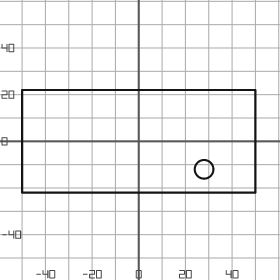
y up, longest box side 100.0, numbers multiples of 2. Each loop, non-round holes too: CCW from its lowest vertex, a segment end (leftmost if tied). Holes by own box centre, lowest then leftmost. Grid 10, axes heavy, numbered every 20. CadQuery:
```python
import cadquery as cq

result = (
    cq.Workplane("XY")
    .moveTo(-50.0, -22.0)
    .lineTo(50.0, -22.0)
    .lineTo(50.0, 22.0)
    .lineTo(-50.0, 22.0)
    .close()
    .moveTo(28.0, -12.0)
    .circle(4.0)
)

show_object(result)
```